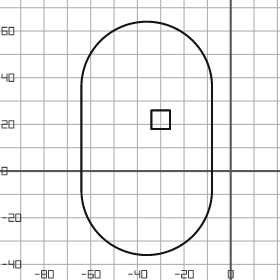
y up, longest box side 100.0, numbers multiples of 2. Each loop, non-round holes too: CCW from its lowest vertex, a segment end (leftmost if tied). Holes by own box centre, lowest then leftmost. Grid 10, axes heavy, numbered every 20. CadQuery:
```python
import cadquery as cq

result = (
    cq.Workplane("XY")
    .moveTo(-64.0, -8.0)
    .threePointArc((-36.0, -36.0), (-8.0, -8.0))
    .lineTo(-8.0, 36.0)
    .threePointArc((-36.0, 64.0), (-64.0, 36.0))
    .close()
    .moveTo(-34.0, 18.0)
    .lineTo(-26.0, 18.0)
    .lineTo(-26.0, 26.0)
    .lineTo(-34.0, 26.0)
    .close()
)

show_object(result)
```